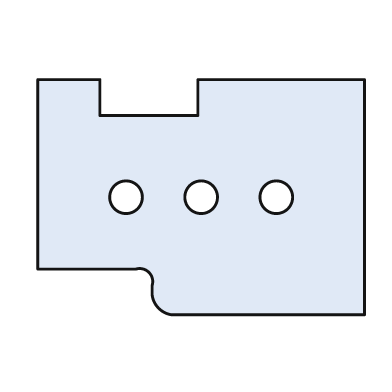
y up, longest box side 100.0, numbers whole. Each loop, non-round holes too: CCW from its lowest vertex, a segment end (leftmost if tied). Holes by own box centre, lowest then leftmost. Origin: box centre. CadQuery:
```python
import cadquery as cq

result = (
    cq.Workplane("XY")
    .moveTo(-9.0, -36.0)
    .lineTo(50.0, -36.0)
    .lineTo(50.0, 36.0)
    .lineTo(-1.0, 36.0)
    .lineTo(-1.0, 25.0)
    .lineTo(-31.0, 25.0)
    .lineTo(-31.0, 36.0)
    .lineTo(-50.0, 36.0)
    .lineTo(-50.0, -22.0)
    .lineTo(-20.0, -22.0)
    .threePointArc((-16.0, -23.0), (-15.0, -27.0))
    .lineTo(-15.0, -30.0)
    .threePointArc((-13.0, -34.0), (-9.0, -36.0))
    .close()
    .moveTo(-23.0, 0.0)
    .circle(5.0)
    .moveTo(0.0, 0.0)
    .circle(5.0)
    .moveTo(23.0, 0.0)
    .circle(5.0)
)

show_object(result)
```